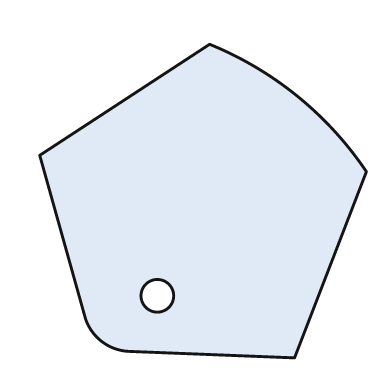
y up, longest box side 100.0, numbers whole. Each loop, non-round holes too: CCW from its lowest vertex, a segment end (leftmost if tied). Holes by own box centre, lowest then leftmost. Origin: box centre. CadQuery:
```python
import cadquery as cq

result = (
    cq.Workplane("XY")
    .moveTo(28.0, -48.0)
    .lineTo(50.0, 9.0)
    .threePointArc((29.0, 32.0), (2.0, 48.0))
    .lineTo(-50.0, 14.0)
    .lineTo(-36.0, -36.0)
    .threePointArc((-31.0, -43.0), (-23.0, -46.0))
    .close()
    .moveTo(-14.0, -29.0)
    .circle(5.0)
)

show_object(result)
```